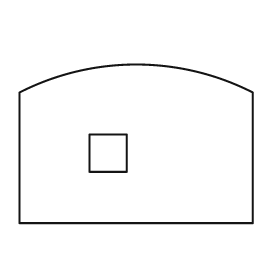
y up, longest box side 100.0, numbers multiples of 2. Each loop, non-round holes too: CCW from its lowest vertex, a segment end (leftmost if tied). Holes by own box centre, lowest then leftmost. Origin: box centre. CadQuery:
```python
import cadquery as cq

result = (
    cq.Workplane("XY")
    .moveTo(-50.0, -34.0)
    .lineTo(50.0, -34.0)
    .lineTo(50.0, 22.0)
    .threePointArc((0.0, 34.0), (-50.0, 22.0))
    .close()
    .moveTo(-20.0, -12.0)
    .lineTo(-4.0, -12.0)
    .lineTo(-4.0, 4.0)
    .lineTo(-20.0, 4.0)
    .close()
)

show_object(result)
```